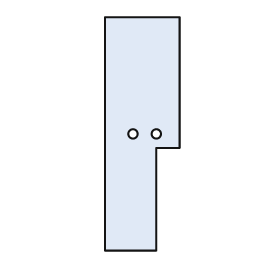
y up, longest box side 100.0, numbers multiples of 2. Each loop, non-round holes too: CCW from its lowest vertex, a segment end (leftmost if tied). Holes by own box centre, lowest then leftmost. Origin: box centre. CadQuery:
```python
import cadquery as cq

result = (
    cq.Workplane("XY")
    .moveTo(-16.0, -50.0)
    .lineTo(6.0, -50.0)
    .lineTo(6.0, -6.0)
    .lineTo(16.0, -6.0)
    .lineTo(16.0, 50.0)
    .lineTo(-16.0, 50.0)
    .close()
    .moveTo(-4.0, 0.0)
    .circle(2.0)
    .moveTo(6.0, 0.0)
    .circle(2.0)
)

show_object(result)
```